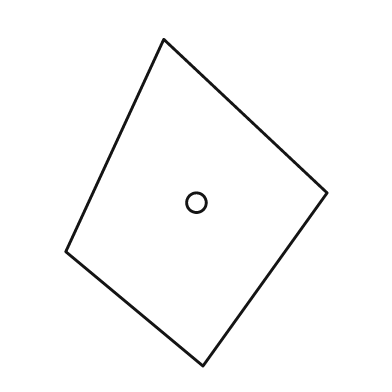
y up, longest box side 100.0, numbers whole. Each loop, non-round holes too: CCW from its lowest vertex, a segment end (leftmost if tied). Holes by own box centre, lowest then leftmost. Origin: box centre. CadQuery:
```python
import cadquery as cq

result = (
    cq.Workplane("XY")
    .moveTo(2.0, -50.0)
    .lineTo(40.0, 3.0)
    .lineTo(-10.0, 50.0)
    .lineTo(-40.0, -15.0)
    .close()
    .moveTo(0.0, 0.0)
    .circle(3.0)
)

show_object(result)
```